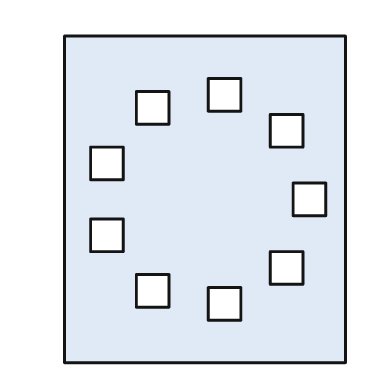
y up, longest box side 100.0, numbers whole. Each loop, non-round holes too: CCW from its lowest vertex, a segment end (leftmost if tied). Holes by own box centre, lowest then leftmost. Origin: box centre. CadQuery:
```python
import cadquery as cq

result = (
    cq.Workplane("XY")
    .moveTo(-43.0, -50.0)
    .lineTo(43.0, -50.0)
    .lineTo(43.0, 50.0)
    .lineTo(-43.0, 50.0)
    .close()
    .moveTo(1.0, -37.0)
    .lineTo(11.0, -37.0)
    .lineTo(11.0, -27.0)
    .lineTo(1.0, -27.0)
    .close()
    .moveTo(-21.0, -33.0)
    .lineTo(-11.0, -33.0)
    .lineTo(-11.0, -23.0)
    .lineTo(-21.0, -23.0)
    .close()
    .moveTo(20.0, -26.0)
    .lineTo(30.0, -26.0)
    .lineTo(30.0, -16.0)
    .lineTo(20.0, -16.0)
    .close()
    .moveTo(-35.0, -16.0)
    .lineTo(-25.0, -16.0)
    .lineTo(-25.0, -6.0)
    .lineTo(-35.0, -6.0)
    .close()
    .moveTo(27.0, -5.0)
    .lineTo(37.0, -5.0)
    .lineTo(37.0, 5.0)
    .lineTo(27.0, 5.0)
    .close()
    .moveTo(-35.0, 6.0)
    .lineTo(-25.0, 6.0)
    .lineTo(-25.0, 16.0)
    .lineTo(-35.0, 16.0)
    .close()
    .moveTo(20.0, 16.0)
    .lineTo(30.0, 16.0)
    .lineTo(30.0, 26.0)
    .lineTo(20.0, 26.0)
    .close()
    .moveTo(-21.0, 23.0)
    .lineTo(-11.0, 23.0)
    .lineTo(-11.0, 33.0)
    .lineTo(-21.0, 33.0)
    .close()
    .moveTo(1.0, 27.0)
    .lineTo(11.0, 27.0)
    .lineTo(11.0, 37.0)
    .lineTo(1.0, 37.0)
    .close()
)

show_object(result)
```